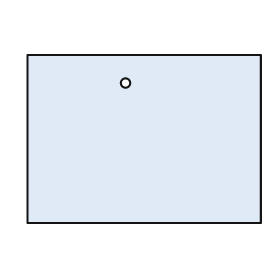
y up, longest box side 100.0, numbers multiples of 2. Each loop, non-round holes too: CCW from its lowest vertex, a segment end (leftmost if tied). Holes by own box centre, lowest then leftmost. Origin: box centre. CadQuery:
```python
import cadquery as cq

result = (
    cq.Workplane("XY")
    .moveTo(-50.0, -36.0)
    .lineTo(50.0, -36.0)
    .lineTo(50.0, 36.0)
    .lineTo(-50.0, 36.0)
    .close()
    .moveTo(-8.0, 24.0)
    .circle(2.0)
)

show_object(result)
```